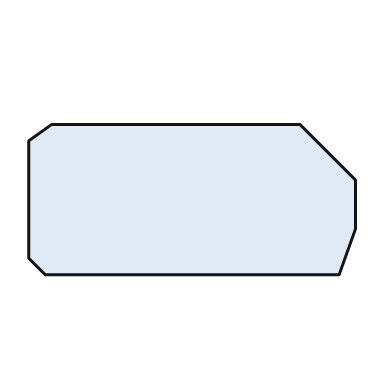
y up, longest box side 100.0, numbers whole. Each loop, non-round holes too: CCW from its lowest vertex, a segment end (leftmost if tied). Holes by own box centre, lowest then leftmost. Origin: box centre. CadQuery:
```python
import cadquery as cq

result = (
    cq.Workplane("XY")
    .moveTo(-45.0, -23.0)
    .lineTo(45.0, -23.0)
    .lineTo(50.0, -9.0)
    .lineTo(50.0, 6.0)
    .lineTo(33.0, 23.0)
    .lineTo(-43.0, 23.0)
    .lineTo(-50.0, 18.0)
    .lineTo(-50.0, -18.0)
    .close()
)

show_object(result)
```